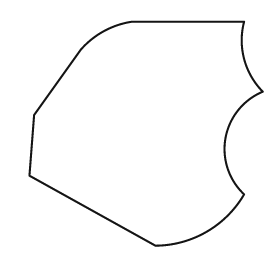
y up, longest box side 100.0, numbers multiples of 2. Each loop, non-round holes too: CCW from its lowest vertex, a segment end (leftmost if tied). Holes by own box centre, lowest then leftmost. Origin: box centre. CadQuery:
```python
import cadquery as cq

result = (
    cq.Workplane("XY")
    .moveTo(4.0, -48.0)
    .threePointArc((26.0, -42.0), (42.0, -26.0))
    .threePointArc((34.0, -2.0), (50.0, 18.0))
    .threePointArc((42.0, 32.0), (42.0, 48.0))
    .lineTo(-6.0, 48.0)
    .threePointArc((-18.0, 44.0), (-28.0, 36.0))
    .lineTo(-48.0, 8.0)
    .lineTo(-50.0, -18.0)
    .close()
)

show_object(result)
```